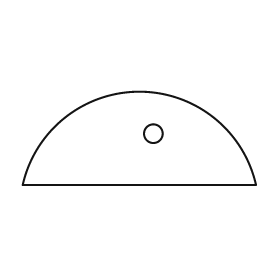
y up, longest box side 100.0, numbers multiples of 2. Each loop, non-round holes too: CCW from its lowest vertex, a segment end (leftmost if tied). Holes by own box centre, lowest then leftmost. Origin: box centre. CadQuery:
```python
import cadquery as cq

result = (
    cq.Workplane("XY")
    .moveTo(-50.0, -20.0)
    .lineTo(50.0, -20.0)
    .threePointArc((0.0, 20.0), (-50.0, -20.0))
    .close()
    .moveTo(6.0, 2.0)
    .circle(4.0)
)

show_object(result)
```